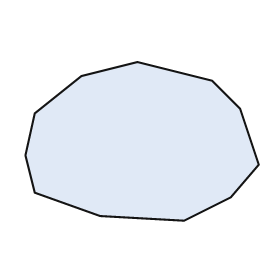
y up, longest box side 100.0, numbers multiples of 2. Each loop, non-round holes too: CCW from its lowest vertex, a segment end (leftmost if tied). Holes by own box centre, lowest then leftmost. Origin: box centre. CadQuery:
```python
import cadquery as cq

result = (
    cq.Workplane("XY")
    .moveTo(18.0, -34.0)
    .lineTo(38.0, -24.0)
    .lineTo(50.0, -10.0)
    .lineTo(42.0, 14.0)
    .lineTo(30.0, 26.0)
    .lineTo(-2.0, 34.0)
    .lineTo(-26.0, 28.0)
    .lineTo(-46.0, 12.0)
    .lineTo(-50.0, -6.0)
    .lineTo(-46.0, -22.0)
    .lineTo(-18.0, -32.0)
    .close()
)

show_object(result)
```